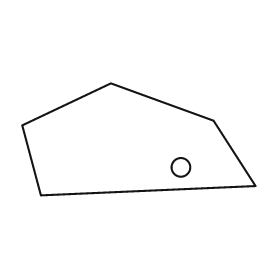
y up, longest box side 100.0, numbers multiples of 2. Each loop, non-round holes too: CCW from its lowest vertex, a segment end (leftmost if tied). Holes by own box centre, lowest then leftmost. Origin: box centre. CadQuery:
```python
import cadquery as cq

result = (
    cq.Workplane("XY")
    .moveTo(-42.0, -24.0)
    .lineTo(50.0, -20.0)
    .lineTo(32.0, 8.0)
    .lineTo(-12.0, 24.0)
    .lineTo(-50.0, 6.0)
    .close()
    .moveTo(18.0, -12.0)
    .circle(4.0)
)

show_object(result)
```